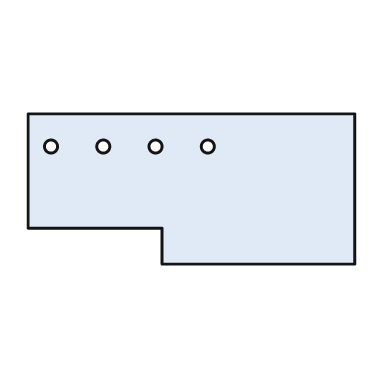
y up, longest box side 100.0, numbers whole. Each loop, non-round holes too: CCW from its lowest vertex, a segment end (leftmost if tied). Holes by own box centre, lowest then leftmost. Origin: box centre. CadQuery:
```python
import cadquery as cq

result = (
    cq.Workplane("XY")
    .moveTo(-9.0, -23.0)
    .lineTo(50.0, -23.0)
    .lineTo(50.0, 23.0)
    .lineTo(-50.0, 23.0)
    .lineTo(-50.0, -12.0)
    .lineTo(-9.0, -12.0)
    .close()
    .moveTo(-43.0, 13.0)
    .circle(2.0)
    .moveTo(-27.0, 13.0)
    .circle(2.0)
    .moveTo(-11.0, 13.0)
    .circle(2.0)
    .moveTo(5.0, 13.0)
    .circle(2.0)
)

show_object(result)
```